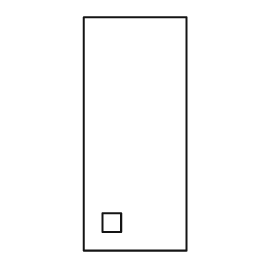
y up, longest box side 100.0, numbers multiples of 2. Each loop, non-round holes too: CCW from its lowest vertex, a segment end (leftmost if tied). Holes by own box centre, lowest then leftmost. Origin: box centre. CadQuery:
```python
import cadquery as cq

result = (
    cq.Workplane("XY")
    .moveTo(-22.0, -50.0)
    .lineTo(22.0, -50.0)
    .lineTo(22.0, 50.0)
    .lineTo(-22.0, 50.0)
    .close()
    .moveTo(-14.0, -42.0)
    .lineTo(-6.0, -42.0)
    .lineTo(-6.0, -34.0)
    .lineTo(-14.0, -34.0)
    .close()
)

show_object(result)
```